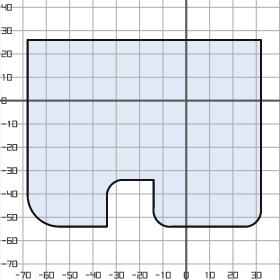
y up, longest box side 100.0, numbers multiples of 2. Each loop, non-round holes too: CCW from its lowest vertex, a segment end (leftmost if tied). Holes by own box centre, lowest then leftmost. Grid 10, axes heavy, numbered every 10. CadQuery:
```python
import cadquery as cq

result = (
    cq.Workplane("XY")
    .moveTo(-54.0, -54.0)
    .lineTo(-34.0, -54.0)
    .lineTo(-34.0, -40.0)
    .threePointArc((-32.0, -36.0), (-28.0, -34.0))
    .lineTo(-14.0, -34.0)
    .lineTo(-14.0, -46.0)
    .threePointArc((-12.0, -52.0), (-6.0, -54.0))
    .lineTo(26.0, -54.0)
    .threePointArc((30.0, -52.0), (32.0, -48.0))
    .lineTo(32.0, 26.0)
    .lineTo(-68.0, 26.0)
    .lineTo(-68.0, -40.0)
    .threePointArc((-64.0, -50.0), (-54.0, -54.0))
    .close()
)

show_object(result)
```